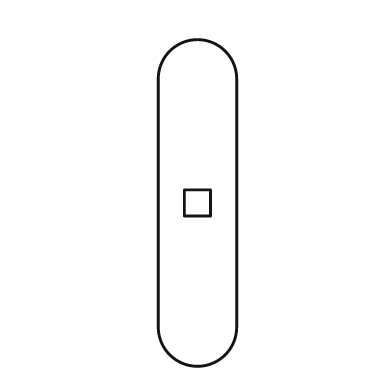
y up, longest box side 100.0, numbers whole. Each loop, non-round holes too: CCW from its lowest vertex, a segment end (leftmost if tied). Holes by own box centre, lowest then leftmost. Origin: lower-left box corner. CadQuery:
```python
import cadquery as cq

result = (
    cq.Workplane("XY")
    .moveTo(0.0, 12.0)
    .threePointArc((12.0, 0.0), (24.0, 12.0))
    .lineTo(24.0, 88.0)
    .threePointArc((12.0, 100.0), (0.0, 88.0))
    .close()
    .moveTo(8.0, 46.0)
    .lineTo(16.0, 46.0)
    .lineTo(16.0, 54.0)
    .lineTo(8.0, 54.0)
    .close()
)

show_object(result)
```